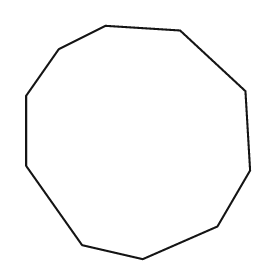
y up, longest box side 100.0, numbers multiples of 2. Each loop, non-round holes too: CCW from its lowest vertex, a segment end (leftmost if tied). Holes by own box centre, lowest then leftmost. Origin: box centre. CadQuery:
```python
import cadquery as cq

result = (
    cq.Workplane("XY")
    .moveTo(2.0, -50.0)
    .lineTo(34.0, -36.0)
    .lineTo(48.0, -12.0)
    .lineTo(46.0, 22.0)
    .lineTo(18.0, 48.0)
    .lineTo(-14.0, 50.0)
    .lineTo(-34.0, 40.0)
    .lineTo(-48.0, 20.0)
    .lineTo(-48.0, -10.0)
    .lineTo(-24.0, -44.0)
    .close()
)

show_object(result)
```